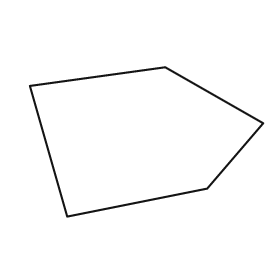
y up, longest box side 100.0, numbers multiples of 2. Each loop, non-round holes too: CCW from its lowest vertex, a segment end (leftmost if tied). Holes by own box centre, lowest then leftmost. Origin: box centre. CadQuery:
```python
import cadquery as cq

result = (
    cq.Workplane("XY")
    .moveTo(-34.0, -32.0)
    .lineTo(26.0, -20.0)
    .lineTo(50.0, 8.0)
    .lineTo(8.0, 32.0)
    .lineTo(-50.0, 24.0)
    .close()
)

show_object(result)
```